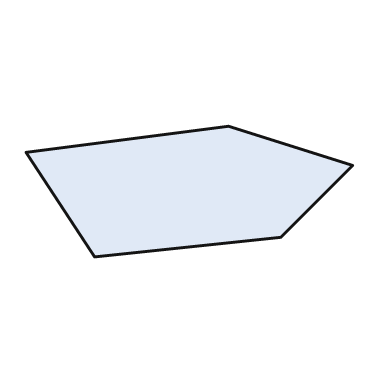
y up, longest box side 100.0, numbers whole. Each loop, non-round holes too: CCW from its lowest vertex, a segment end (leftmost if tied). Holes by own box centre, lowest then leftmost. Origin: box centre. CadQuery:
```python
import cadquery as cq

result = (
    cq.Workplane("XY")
    .moveTo(-29.0, -20.0)
    .lineTo(28.0, -14.0)
    .lineTo(50.0, 8.0)
    .lineTo(12.0, 20.0)
    .lineTo(-50.0, 12.0)
    .close()
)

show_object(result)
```